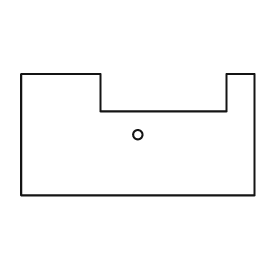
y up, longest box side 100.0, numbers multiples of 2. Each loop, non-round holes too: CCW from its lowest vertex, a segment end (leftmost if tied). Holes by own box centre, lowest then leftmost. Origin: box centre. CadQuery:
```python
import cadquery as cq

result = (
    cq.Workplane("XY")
    .moveTo(-50.0, -26.0)
    .lineTo(50.0, -26.0)
    .lineTo(50.0, 26.0)
    .lineTo(38.0, 26.0)
    .lineTo(38.0, 10.0)
    .lineTo(-16.0, 10.0)
    .lineTo(-16.0, 26.0)
    .lineTo(-50.0, 26.0)
    .close()
    .moveTo(0.0, 0.0)
    .circle(2.0)
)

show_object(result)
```